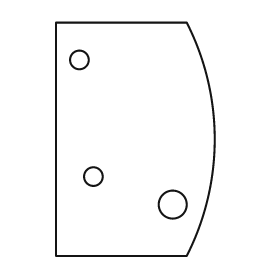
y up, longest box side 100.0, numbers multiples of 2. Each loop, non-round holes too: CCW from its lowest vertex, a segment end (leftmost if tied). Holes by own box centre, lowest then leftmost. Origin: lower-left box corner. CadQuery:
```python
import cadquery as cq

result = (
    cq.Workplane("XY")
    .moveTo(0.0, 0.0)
    .lineTo(56.0, 0.0)
    .threePointArc((68.0, 50.0), (56.0, 100.0))
    .lineTo(0.0, 100.0)
    .close()
    .moveTo(50.0, 22.0)
    .circle(6.0)
    .moveTo(16.0, 34.0)
    .circle(4.0)
    .moveTo(10.0, 84.0)
    .circle(4.0)
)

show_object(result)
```